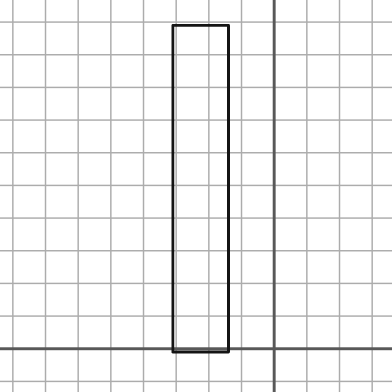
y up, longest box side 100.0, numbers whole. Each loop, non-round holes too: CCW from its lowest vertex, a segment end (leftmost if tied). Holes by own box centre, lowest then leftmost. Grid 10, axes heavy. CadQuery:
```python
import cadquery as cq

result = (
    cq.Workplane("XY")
    .moveTo(-31.0, -1.0)
    .lineTo(-14.0, -1.0)
    .lineTo(-14.0, 99.0)
    .lineTo(-31.0, 99.0)
    .close()
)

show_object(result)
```